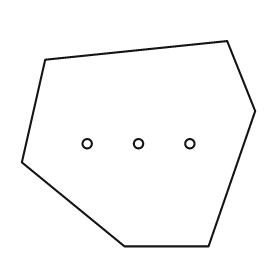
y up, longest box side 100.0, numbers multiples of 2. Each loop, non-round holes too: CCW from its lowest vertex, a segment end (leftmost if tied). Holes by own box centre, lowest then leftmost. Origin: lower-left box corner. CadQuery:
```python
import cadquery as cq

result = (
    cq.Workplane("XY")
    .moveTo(44.0, 0.0)
    .lineTo(80.0, 0.0)
    .lineTo(100.0, 58.0)
    .lineTo(88.0, 88.0)
    .lineTo(10.0, 80.0)
    .lineTo(0.0, 36.0)
    .close()
    .moveTo(28.0, 44.0)
    .circle(2.0)
    .moveTo(50.0, 44.0)
    .circle(2.0)
    .moveTo(72.0, 44.0)
    .circle(2.0)
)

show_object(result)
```